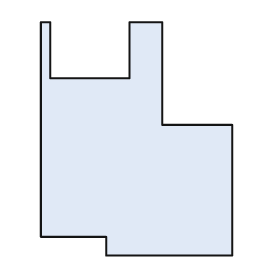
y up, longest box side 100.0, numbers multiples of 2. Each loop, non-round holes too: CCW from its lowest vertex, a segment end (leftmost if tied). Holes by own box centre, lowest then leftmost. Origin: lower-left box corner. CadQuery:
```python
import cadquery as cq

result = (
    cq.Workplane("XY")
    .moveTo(28.0, 0.0)
    .lineTo(82.0, 0.0)
    .lineTo(82.0, 56.0)
    .lineTo(52.0, 56.0)
    .lineTo(52.0, 100.0)
    .lineTo(38.0, 100.0)
    .lineTo(38.0, 76.0)
    .lineTo(4.0, 76.0)
    .lineTo(4.0, 100.0)
    .lineTo(0.0, 100.0)
    .lineTo(0.0, 8.0)
    .lineTo(28.0, 8.0)
    .close()
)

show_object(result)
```